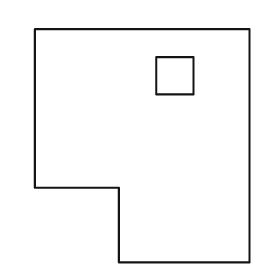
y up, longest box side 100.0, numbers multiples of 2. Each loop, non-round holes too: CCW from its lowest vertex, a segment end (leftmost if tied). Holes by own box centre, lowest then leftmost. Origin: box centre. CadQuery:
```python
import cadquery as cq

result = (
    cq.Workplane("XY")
    .moveTo(-10.0, -50.0)
    .lineTo(46.0, -50.0)
    .lineTo(46.0, 50.0)
    .lineTo(-46.0, 50.0)
    .lineTo(-46.0, -18.0)
    .lineTo(-10.0, -18.0)
    .close()
    .moveTo(6.0, 22.0)
    .lineTo(22.0, 22.0)
    .lineTo(22.0, 38.0)
    .lineTo(6.0, 38.0)
    .close()
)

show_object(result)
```